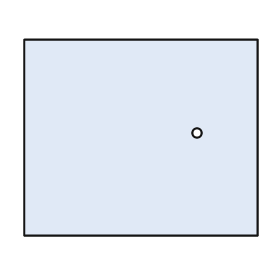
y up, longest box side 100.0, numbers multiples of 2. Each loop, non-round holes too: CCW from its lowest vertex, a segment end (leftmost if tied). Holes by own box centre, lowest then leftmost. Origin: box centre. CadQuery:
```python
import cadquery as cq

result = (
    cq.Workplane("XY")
    .moveTo(-50.0, -42.0)
    .lineTo(50.0, -42.0)
    .lineTo(50.0, 42.0)
    .lineTo(-50.0, 42.0)
    .close()
    .moveTo(24.0, 2.0)
    .circle(2.0)
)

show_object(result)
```